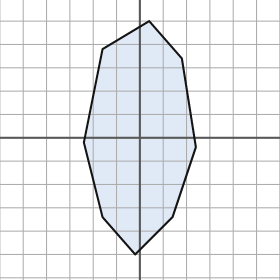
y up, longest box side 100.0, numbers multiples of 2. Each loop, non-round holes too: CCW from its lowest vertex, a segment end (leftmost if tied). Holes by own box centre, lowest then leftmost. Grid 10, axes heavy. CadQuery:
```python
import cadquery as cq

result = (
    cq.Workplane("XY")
    .moveTo(-2.0, -50.0)
    .lineTo(14.0, -34.0)
    .lineTo(24.0, -4.0)
    .lineTo(18.0, 34.0)
    .lineTo(4.0, 50.0)
    .lineTo(-16.0, 38.0)
    .lineTo(-24.0, -2.0)
    .lineTo(-16.0, -34.0)
    .close()
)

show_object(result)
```